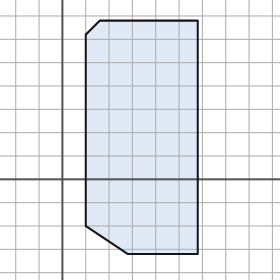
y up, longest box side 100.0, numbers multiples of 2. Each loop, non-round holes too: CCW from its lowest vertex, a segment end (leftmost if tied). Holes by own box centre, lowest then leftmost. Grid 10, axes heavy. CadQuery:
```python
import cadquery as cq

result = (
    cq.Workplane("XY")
    .moveTo(28.0, -32.0)
    .lineTo(58.0, -32.0)
    .lineTo(58.0, 68.0)
    .lineTo(16.0, 68.0)
    .lineTo(10.0, 62.0)
    .lineTo(10.0, -20.0)
    .close()
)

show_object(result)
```